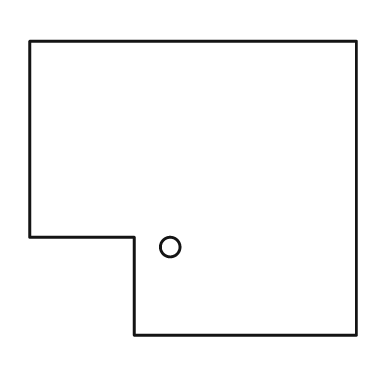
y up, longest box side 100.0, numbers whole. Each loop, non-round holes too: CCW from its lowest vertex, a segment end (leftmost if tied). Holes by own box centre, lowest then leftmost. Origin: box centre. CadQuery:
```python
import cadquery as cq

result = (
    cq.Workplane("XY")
    .moveTo(-18.0, -45.0)
    .lineTo(50.0, -45.0)
    .lineTo(50.0, 45.0)
    .lineTo(-50.0, 45.0)
    .lineTo(-50.0, -15.0)
    .lineTo(-18.0, -15.0)
    .close()
    .moveTo(-7.0, -18.0)
    .circle(3.0)
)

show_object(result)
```